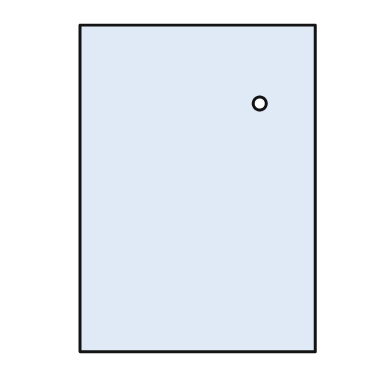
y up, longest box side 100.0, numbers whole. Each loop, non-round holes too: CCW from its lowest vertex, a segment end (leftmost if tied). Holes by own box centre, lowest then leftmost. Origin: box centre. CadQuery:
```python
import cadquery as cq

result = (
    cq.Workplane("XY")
    .moveTo(-36.0, -50.0)
    .lineTo(36.0, -50.0)
    .lineTo(36.0, 50.0)
    .lineTo(-36.0, 50.0)
    .close()
    .moveTo(19.0, 26.0)
    .circle(2.0)
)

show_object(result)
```